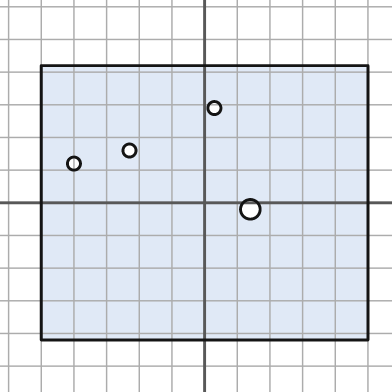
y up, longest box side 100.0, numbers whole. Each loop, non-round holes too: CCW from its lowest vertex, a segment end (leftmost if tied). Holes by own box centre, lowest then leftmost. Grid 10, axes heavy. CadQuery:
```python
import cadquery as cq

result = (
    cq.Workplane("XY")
    .moveTo(-50.0, -42.0)
    .lineTo(50.0, -42.0)
    .lineTo(50.0, 42.0)
    .lineTo(-50.0, 42.0)
    .close()
    .moveTo(14.0, -2.0)
    .circle(3.0)
    .moveTo(-40.0, 12.0)
    .circle(2.0)
    .moveTo(-23.0, 16.0)
    .circle(2.0)
    .moveTo(3.0, 29.0)
    .circle(2.0)
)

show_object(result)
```